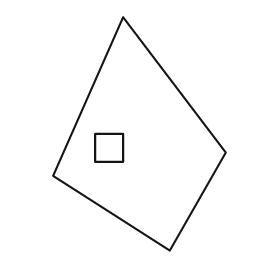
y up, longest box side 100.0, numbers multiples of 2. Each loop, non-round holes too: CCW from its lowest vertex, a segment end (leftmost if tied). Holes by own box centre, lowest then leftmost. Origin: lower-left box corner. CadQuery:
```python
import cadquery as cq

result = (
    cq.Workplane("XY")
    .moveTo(50.0, 0.0)
    .lineTo(74.0, 42.0)
    .lineTo(30.0, 100.0)
    .lineTo(0.0, 32.0)
    .close()
    .moveTo(18.0, 38.0)
    .lineTo(30.0, 38.0)
    .lineTo(30.0, 50.0)
    .lineTo(18.0, 50.0)
    .close()
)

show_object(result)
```